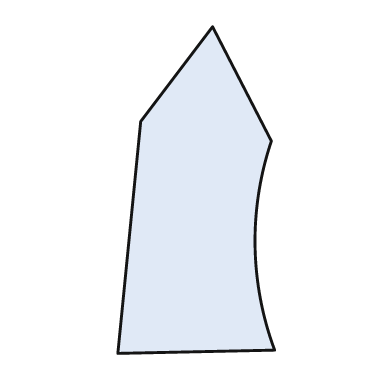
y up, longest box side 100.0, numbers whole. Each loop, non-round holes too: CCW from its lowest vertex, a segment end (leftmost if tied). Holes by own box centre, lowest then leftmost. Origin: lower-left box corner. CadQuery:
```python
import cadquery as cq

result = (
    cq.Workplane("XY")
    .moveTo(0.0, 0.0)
    .lineTo(48.0, 1.0)
    .threePointArc((42.0, 33.0), (47.0, 65.0))
    .lineTo(29.0, 100.0)
    .lineTo(7.0, 71.0)
    .close()
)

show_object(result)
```